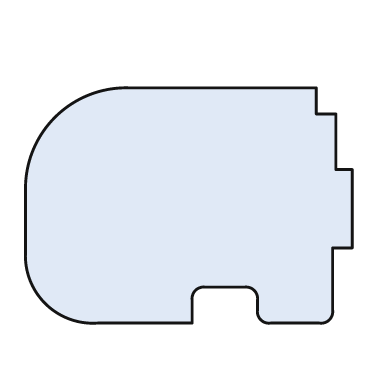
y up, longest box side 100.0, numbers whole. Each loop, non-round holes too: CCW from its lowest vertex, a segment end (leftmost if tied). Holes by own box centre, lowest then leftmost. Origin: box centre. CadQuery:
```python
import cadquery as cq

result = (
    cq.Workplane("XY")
    .moveTo(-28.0, -36.0)
    .lineTo(1.0, -36.0)
    .lineTo(1.0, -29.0)
    .threePointArc((2.0, -26.0), (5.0, -25.0))
    .lineTo(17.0, -25.0)
    .threePointArc((20.0, -26.0), (21.0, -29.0))
    .lineTo(21.0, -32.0)
    .threePointArc((22.0, -35.0), (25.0, -36.0))
    .lineTo(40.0, -36.0)
    .threePointArc((43.0, -35.0), (44.0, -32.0))
    .lineTo(44.0, -13.0)
    .lineTo(50.0, -13.0)
    .lineTo(50.0, 11.0)
    .lineTo(45.0, 11.0)
    .lineTo(45.0, 28.0)
    .lineTo(39.0, 28.0)
    .lineTo(39.0, 36.0)
    .lineTo(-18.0, 36.0)
    .threePointArc((-41.0, 27.0), (-50.0, 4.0))
    .lineTo(-50.0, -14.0)
    .threePointArc((-44.0, -30.0), (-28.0, -36.0))
    .close()
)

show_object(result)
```